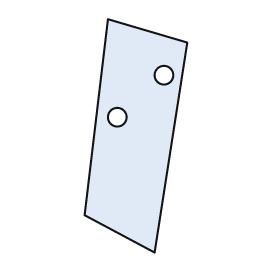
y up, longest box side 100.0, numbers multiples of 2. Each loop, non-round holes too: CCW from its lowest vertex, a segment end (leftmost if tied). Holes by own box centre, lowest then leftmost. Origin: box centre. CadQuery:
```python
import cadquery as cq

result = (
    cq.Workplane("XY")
    .moveTo(8.0, -50.0)
    .lineTo(22.0, 40.0)
    .lineTo(-12.0, 50.0)
    .lineTo(-22.0, -34.0)
    .close()
    .moveTo(-8.0, 8.0)
    .circle(4.0)
    .moveTo(12.0, 26.0)
    .circle(4.0)
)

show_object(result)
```